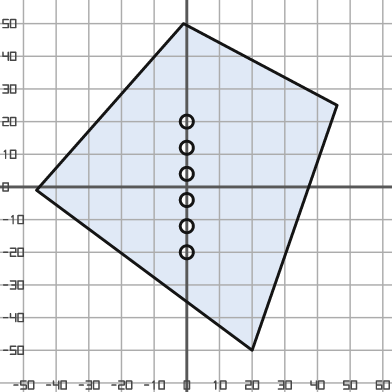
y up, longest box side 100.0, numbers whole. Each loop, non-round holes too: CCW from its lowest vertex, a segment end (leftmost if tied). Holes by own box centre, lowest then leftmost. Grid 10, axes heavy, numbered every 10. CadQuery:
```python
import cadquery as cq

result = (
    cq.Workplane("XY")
    .moveTo(20.0, -50.0)
    .lineTo(46.0, 25.0)
    .lineTo(-1.0, 50.0)
    .lineTo(-46.0, -1.0)
    .close()
    .moveTo(0.0, -20.0)
    .circle(2.0)
    .moveTo(0.0, -12.0)
    .circle(2.0)
    .moveTo(0.0, -4.0)
    .circle(2.0)
    .moveTo(0.0, 4.0)
    .circle(2.0)
    .moveTo(0.0, 12.0)
    .circle(2.0)
    .moveTo(0.0, 20.0)
    .circle(2.0)
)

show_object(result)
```